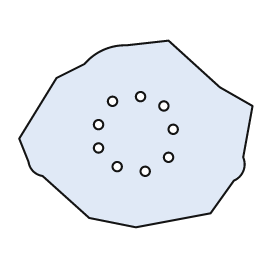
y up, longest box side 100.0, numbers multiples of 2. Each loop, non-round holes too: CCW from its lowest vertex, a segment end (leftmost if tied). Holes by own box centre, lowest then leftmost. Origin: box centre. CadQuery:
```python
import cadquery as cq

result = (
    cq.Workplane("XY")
    .moveTo(0.0, -40.0)
    .lineTo(32.0, -34.0)
    .lineTo(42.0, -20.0)
    .threePointArc((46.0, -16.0), (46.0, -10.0))
    .lineTo(50.0, 12.0)
    .lineTo(36.0, 20.0)
    .lineTo(14.0, 40.0)
    .lineTo(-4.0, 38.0)
    .threePointArc((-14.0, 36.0), (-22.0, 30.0))
    .lineTo(-34.0, 24.0)
    .lineTo(-50.0, -2.0)
    .lineTo(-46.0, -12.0)
    .threePointArc((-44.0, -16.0), (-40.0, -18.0))
    .lineTo(-20.0, -36.0)
    .close()
    .moveTo(4.0, -16.0)
    .circle(2.0)
    .moveTo(-8.0, -14.0)
    .circle(2.0)
    .moveTo(14.0, -10.0)
    .circle(2.0)
    .moveTo(-16.0, -6.0)
    .circle(2.0)
    .moveTo(16.0, 2.0)
    .circle(2.0)
    .moveTo(-16.0, 4.0)
    .circle(2.0)
    .moveTo(12.0, 12.0)
    .circle(2.0)
    .moveTo(-10.0, 14.0)
    .circle(2.0)
    .moveTo(2.0, 16.0)
    .circle(2.0)
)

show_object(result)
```